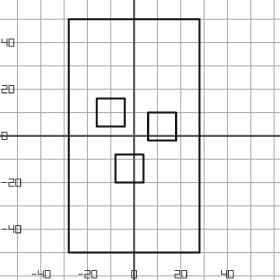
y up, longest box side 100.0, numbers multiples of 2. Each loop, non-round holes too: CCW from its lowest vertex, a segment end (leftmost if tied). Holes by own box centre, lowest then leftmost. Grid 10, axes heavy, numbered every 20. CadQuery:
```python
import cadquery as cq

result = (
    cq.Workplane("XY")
    .moveTo(-28.0, -50.0)
    .lineTo(28.0, -50.0)
    .lineTo(28.0, 50.0)
    .lineTo(-28.0, 50.0)
    .close()
    .moveTo(-8.0, -20.0)
    .lineTo(4.0, -20.0)
    .lineTo(4.0, -8.0)
    .lineTo(-8.0, -8.0)
    .close()
    .moveTo(6.0, -2.0)
    .lineTo(18.0, -2.0)
    .lineTo(18.0, 10.0)
    .lineTo(6.0, 10.0)
    .close()
    .moveTo(-16.0, 4.0)
    .lineTo(-4.0, 4.0)
    .lineTo(-4.0, 16.0)
    .lineTo(-16.0, 16.0)
    .close()
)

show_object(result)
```